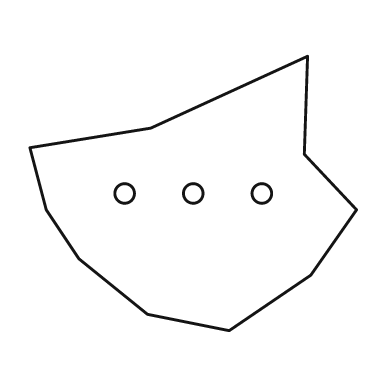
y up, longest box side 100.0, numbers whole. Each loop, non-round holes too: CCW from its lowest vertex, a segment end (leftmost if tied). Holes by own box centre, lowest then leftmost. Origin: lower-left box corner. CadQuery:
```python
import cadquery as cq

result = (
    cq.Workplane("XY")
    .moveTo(61.0, 0.0)
    .lineTo(86.0, 17.0)
    .lineTo(100.0, 37.0)
    .lineTo(84.0, 54.0)
    .lineTo(85.0, 84.0)
    .lineTo(37.0, 62.0)
    .lineTo(0.0, 56.0)
    .lineTo(5.0, 37.0)
    .lineTo(15.0, 22.0)
    .lineTo(36.0, 5.0)
    .close()
    .moveTo(29.0, 42.0)
    .circle(3.0)
    .moveTo(50.0, 42.0)
    .circle(3.0)
    .moveTo(71.0, 42.0)
    .circle(3.0)
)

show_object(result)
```